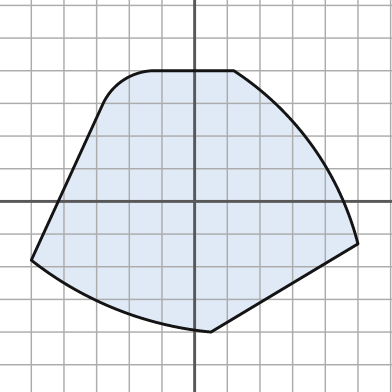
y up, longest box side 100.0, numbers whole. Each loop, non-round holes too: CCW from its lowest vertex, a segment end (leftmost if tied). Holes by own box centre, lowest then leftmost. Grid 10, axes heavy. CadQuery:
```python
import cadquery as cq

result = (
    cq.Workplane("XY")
    .moveTo(5.0, -40.0)
    .lineTo(50.0, -13.0)
    .threePointArc((36.0, 17.0), (12.0, 40.0))
    .lineTo(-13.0, 40.0)
    .threePointArc((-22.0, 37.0), (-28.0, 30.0))
    .lineTo(-50.0, -18.0)
    .threePointArc((-24.0, -33.0), (5.0, -40.0))
    .close()
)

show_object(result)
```